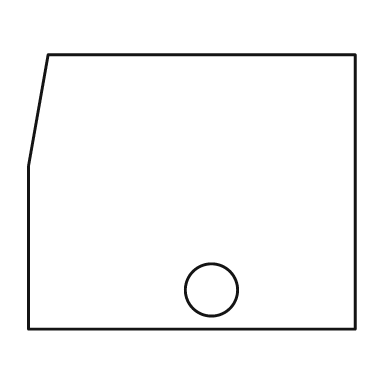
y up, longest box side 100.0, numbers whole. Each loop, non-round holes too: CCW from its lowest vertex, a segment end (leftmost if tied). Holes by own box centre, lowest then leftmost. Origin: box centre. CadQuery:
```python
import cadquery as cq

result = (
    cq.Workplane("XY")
    .moveTo(-50.0, -42.0)
    .lineTo(50.0, -42.0)
    .lineTo(50.0, 42.0)
    .lineTo(-44.0, 42.0)
    .lineTo(-50.0, 8.0)
    .close()
    .moveTo(6.0, -30.0)
    .circle(8.0)
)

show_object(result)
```